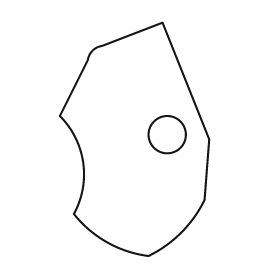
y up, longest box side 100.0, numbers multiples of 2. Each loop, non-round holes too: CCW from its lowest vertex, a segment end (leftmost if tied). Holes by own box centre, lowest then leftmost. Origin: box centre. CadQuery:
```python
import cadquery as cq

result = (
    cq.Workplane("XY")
    .moveTo(6.0, -50.0)
    .threePointArc((20.0, -40.0), (30.0, -26.0))
    .lineTo(32.0, 0.0)
    .lineTo(12.0, 50.0)
    .lineTo(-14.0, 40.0)
    .threePointArc((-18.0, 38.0), (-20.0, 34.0))
    .lineTo(-32.0, 10.0)
    .threePointArc((-22.0, -10.0), (-26.0, -32.0))
    .threePointArc((-12.0, -44.0), (6.0, -50.0))
    .close()
    .moveTo(14.0, 2.0)
    .circle(8.0)
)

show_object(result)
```